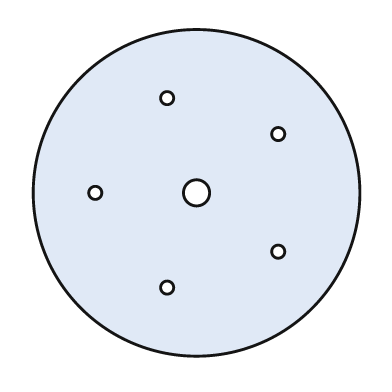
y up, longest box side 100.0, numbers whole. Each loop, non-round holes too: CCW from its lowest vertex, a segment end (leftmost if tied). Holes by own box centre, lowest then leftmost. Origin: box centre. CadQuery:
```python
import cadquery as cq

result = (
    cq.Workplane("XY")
    .moveTo(0.0, 0.0)
    .circle(50.0)
    .moveTo(-9.0, -29.0)
    .circle(2.0)
    .moveTo(25.0, -18.0)
    .circle(2.0)
    .moveTo(-31.0, 0.0)
    .circle(2.0)
    .moveTo(0.0, 0.0)
    .circle(4.0)
    .moveTo(25.0, 18.0)
    .circle(2.0)
    .moveTo(-9.0, 29.0)
    .circle(2.0)
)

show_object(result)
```